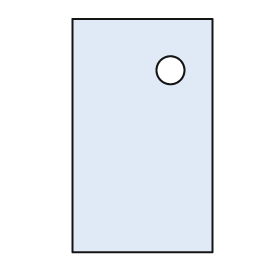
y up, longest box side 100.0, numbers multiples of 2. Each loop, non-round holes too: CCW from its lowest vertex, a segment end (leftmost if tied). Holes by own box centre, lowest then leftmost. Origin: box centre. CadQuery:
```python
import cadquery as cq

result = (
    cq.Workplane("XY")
    .moveTo(-30.0, -50.0)
    .lineTo(30.0, -50.0)
    .lineTo(30.0, 50.0)
    .lineTo(-30.0, 50.0)
    .close()
    .moveTo(12.0, 28.0)
    .circle(6.0)
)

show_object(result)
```